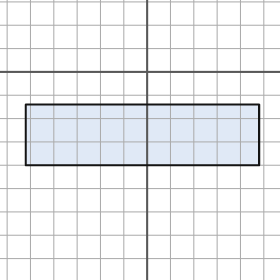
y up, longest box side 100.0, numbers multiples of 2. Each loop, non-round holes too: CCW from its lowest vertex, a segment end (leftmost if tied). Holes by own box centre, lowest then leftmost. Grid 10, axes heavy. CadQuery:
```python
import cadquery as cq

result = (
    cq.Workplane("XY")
    .moveTo(-52.0, -40.0)
    .lineTo(48.0, -40.0)
    .lineTo(48.0, -14.0)
    .lineTo(-52.0, -14.0)
    .close()
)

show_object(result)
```